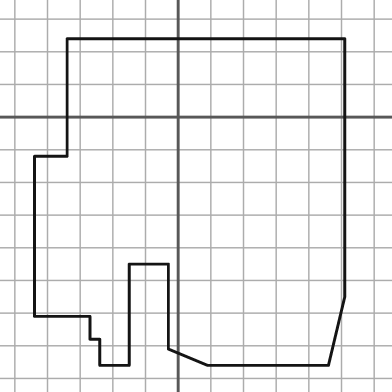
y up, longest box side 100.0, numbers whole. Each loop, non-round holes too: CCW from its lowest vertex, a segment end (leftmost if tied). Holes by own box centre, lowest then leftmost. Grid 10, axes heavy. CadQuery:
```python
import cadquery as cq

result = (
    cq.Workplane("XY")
    .moveTo(-24.0, -76.0)
    .lineTo(-15.0, -76.0)
    .lineTo(-15.0, -45.0)
    .lineTo(-3.0, -45.0)
    .lineTo(-3.0, -71.0)
    .lineTo(9.0, -76.0)
    .lineTo(46.0, -76.0)
    .lineTo(51.0, -55.0)
    .lineTo(51.0, 24.0)
    .lineTo(-34.0, 24.0)
    .lineTo(-34.0, -12.0)
    .lineTo(-44.0, -12.0)
    .lineTo(-44.0, -61.0)
    .lineTo(-27.0, -61.0)
    .lineTo(-27.0, -68.0)
    .lineTo(-24.0, -68.0)
    .close()
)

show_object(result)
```